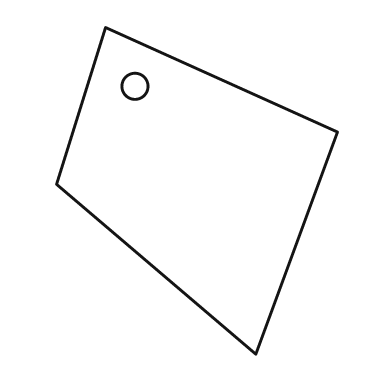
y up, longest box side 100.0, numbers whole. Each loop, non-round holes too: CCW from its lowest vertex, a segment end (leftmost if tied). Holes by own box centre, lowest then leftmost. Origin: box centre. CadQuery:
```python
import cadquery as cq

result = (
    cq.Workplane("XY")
    .moveTo(18.0, -50.0)
    .lineTo(43.0, 18.0)
    .lineTo(-28.0, 50.0)
    .lineTo(-43.0, 2.0)
    .close()
    .moveTo(-19.0, 32.0)
    .circle(4.0)
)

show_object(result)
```